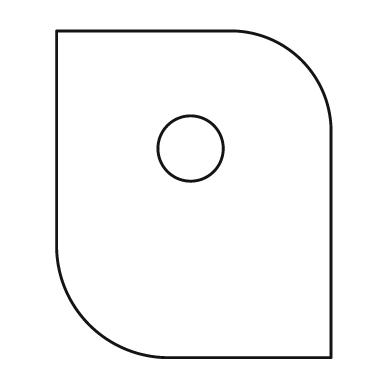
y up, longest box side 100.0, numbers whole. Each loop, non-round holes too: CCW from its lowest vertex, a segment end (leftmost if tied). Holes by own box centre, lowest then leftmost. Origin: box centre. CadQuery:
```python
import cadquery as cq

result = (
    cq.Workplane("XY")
    .moveTo(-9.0, -50.0)
    .lineTo(42.0, -50.0)
    .lineTo(42.0, 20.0)
    .threePointArc((33.0, 41.0), (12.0, 50.0))
    .lineTo(-42.0, 50.0)
    .lineTo(-42.0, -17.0)
    .threePointArc((-32.0, -40.0), (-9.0, -50.0))
    .close()
    .moveTo(-1.0, 14.0)
    .circle(10.0)
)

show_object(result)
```